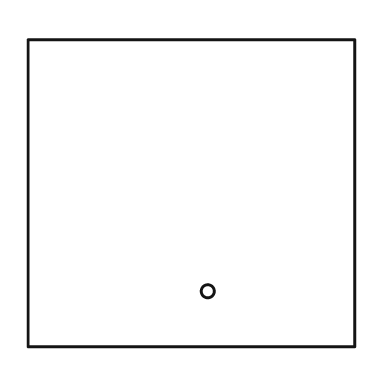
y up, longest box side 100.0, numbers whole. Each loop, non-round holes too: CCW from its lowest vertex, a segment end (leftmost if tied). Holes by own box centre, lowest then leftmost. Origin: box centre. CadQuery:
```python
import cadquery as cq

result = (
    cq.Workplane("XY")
    .moveTo(-50.0, -47.0)
    .lineTo(50.0, -47.0)
    .lineTo(50.0, 47.0)
    .lineTo(-50.0, 47.0)
    .close()
    .moveTo(5.0, -30.0)
    .circle(2.0)
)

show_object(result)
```